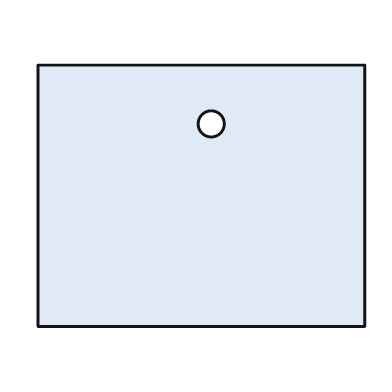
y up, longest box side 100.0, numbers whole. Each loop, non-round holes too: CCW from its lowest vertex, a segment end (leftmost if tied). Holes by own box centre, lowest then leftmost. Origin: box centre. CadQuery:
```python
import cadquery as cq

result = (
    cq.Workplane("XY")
    .moveTo(-50.0, -40.0)
    .lineTo(50.0, -40.0)
    .lineTo(50.0, 40.0)
    .lineTo(-50.0, 40.0)
    .close()
    .moveTo(3.0, 22.0)
    .circle(4.0)
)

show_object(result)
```